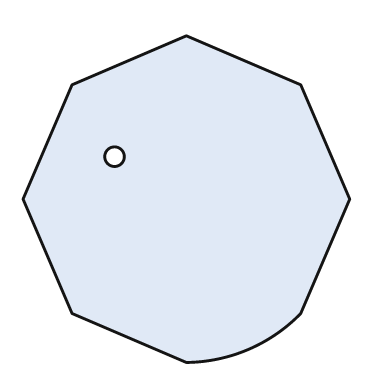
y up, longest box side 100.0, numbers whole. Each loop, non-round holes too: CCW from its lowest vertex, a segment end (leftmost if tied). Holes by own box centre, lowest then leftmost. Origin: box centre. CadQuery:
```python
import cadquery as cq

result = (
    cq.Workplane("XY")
    .moveTo(0.0, -50.0)
    .threePointArc((19.0, -46.0), (35.0, -35.0))
    .lineTo(50.0, 0.0)
    .lineTo(35.0, 35.0)
    .lineTo(0.0, 50.0)
    .lineTo(-35.0, 35.0)
    .lineTo(-50.0, 0.0)
    .lineTo(-35.0, -35.0)
    .close()
    .moveTo(-22.0, 13.0)
    .circle(3.0)
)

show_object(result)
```